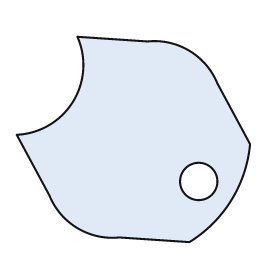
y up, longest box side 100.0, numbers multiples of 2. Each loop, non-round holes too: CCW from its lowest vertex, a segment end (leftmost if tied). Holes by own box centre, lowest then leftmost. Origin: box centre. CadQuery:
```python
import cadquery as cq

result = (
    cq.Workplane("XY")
    .moveTo(24.0, -44.0)
    .threePointArc((42.0, -26.0), (50.0, -2.0))
    .lineTo(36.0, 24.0)
    .threePointArc((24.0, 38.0), (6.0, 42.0))
    .lineTo(-24.0, 44.0)
    .threePointArc((-26.0, 16.0), (-50.0, 2.0))
    .lineTo(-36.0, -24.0)
    .threePointArc((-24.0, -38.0), (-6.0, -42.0))
    .close()
    .moveTo(28.0, -18.0)
    .circle(8.0)
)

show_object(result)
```